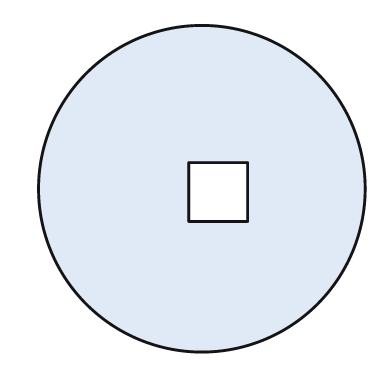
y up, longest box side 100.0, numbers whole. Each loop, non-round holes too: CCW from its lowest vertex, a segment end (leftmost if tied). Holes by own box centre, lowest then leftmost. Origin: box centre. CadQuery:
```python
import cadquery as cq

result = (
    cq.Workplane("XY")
    .moveTo(0.0, 0.0)
    .circle(50.0)
    .moveTo(-4.0, -10.0)
    .lineTo(14.0, -10.0)
    .lineTo(14.0, 8.0)
    .lineTo(-4.0, 8.0)
    .close()
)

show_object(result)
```